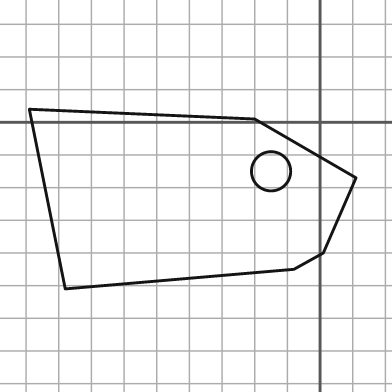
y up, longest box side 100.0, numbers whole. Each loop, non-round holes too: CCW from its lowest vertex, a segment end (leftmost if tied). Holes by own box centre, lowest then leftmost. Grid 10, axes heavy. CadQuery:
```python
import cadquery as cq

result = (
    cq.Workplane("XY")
    .moveTo(-78.0, -51.0)
    .lineTo(-8.0, -45.0)
    .lineTo(1.0, -40.0)
    .lineTo(11.0, -17.0)
    .lineTo(-20.0, 1.0)
    .lineTo(-89.0, 4.0)
    .close()
    .moveTo(-15.0, -15.0)
    .circle(6.0)
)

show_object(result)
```